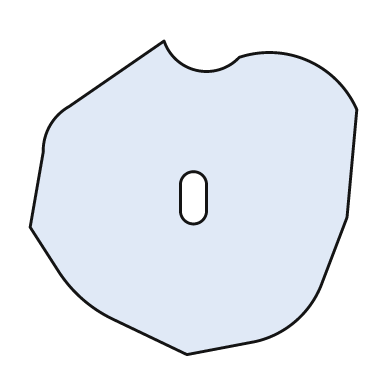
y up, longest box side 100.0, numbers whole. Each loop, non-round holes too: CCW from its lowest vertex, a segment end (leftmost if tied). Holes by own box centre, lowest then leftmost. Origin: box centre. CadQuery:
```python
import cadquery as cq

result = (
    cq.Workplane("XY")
    .moveTo(-2.0, -48.0)
    .lineTo(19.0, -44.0)
    .threePointArc((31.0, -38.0), (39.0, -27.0))
    .lineTo(47.0, -6.0)
    .lineTo(50.0, 27.0)
    .threePointArc((35.0, 42.0), (14.0, 43.0))
    .threePointArc((1.0, 39.0), (-9.0, 48.0))
    .lineTo(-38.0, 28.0)
    .threePointArc((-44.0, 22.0), (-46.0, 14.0))
    .lineTo(-50.0, -9.0)
    .lineTo(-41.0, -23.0)
    .threePointArc((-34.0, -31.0), (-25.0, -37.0))
    .close()
    .moveTo(-4.0, -4.0)
    .threePointArc((0.0, -8.0), (4.0, -4.0))
    .lineTo(4.0, 4.0)
    .threePointArc((0.0, 8.0), (-4.0, 4.0))
    .close()
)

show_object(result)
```